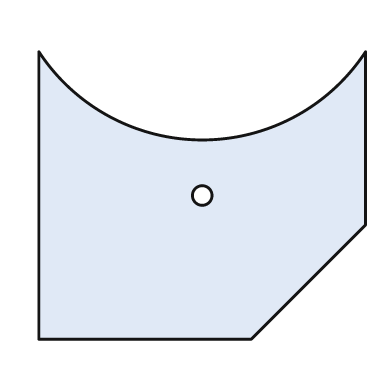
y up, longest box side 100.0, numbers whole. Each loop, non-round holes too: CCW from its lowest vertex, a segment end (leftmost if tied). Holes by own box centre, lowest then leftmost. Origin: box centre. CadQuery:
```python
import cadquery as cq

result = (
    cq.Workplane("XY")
    .moveTo(-50.0, -44.0)
    .lineTo(15.0, -44.0)
    .lineTo(50.0, -9.0)
    .lineTo(50.0, 44.0)
    .threePointArc((0.0, 17.0), (-50.0, 44.0))
    .close()
    .moveTo(0.0, 0.0)
    .circle(3.0)
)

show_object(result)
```